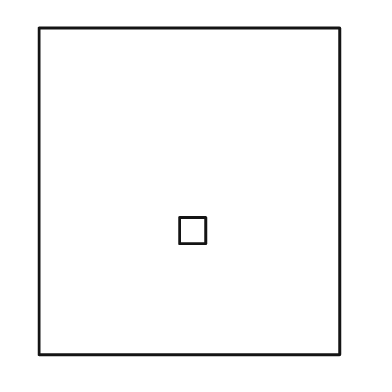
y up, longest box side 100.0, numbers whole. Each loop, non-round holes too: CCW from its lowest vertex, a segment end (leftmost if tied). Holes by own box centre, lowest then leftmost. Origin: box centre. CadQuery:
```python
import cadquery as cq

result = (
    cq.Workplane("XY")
    .moveTo(-46.0, -50.0)
    .lineTo(46.0, -50.0)
    .lineTo(46.0, 50.0)
    .lineTo(-46.0, 50.0)
    .close()
    .moveTo(-3.0, -16.0)
    .lineTo(5.0, -16.0)
    .lineTo(5.0, -8.0)
    .lineTo(-3.0, -8.0)
    .close()
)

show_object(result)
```